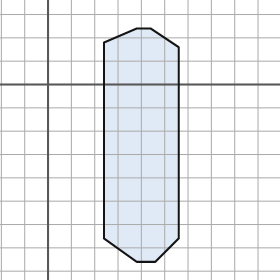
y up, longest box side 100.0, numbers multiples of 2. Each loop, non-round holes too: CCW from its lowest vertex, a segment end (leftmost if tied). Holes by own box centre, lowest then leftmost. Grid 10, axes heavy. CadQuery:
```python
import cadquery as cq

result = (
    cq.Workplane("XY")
    .moveTo(38.0, -76.0)
    .lineTo(46.0, -76.0)
    .lineTo(56.0, -66.0)
    .lineTo(56.0, 16.0)
    .lineTo(44.0, 24.0)
    .lineTo(38.0, 24.0)
    .lineTo(24.0, 18.0)
    .lineTo(24.0, -66.0)
    .close()
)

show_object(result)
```